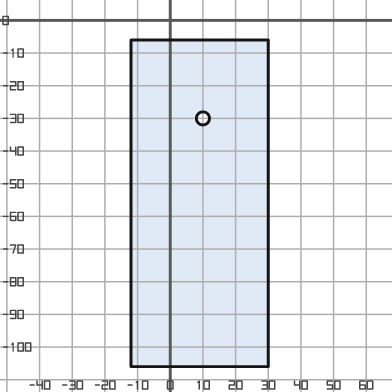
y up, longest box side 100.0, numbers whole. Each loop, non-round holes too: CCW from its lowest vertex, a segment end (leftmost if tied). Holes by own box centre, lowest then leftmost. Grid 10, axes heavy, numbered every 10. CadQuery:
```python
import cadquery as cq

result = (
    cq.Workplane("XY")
    .moveTo(-12.0, -106.0)
    .lineTo(30.0, -106.0)
    .lineTo(30.0, -6.0)
    .lineTo(-12.0, -6.0)
    .close()
    .moveTo(10.0, -30.0)
    .circle(2.0)
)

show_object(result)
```